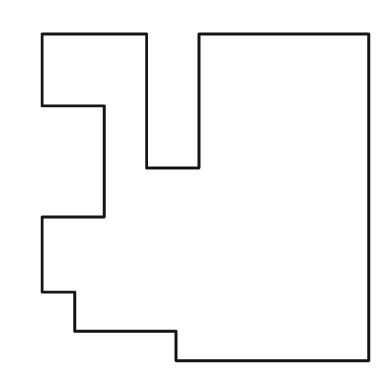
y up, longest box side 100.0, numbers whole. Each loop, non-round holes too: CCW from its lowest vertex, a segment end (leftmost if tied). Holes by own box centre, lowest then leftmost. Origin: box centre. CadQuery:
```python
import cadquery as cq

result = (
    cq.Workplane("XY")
    .moveTo(-9.0, -50.0)
    .lineTo(50.0, -50.0)
    .lineTo(50.0, 50.0)
    .lineTo(-2.0, 50.0)
    .lineTo(-2.0, 9.0)
    .lineTo(-18.0, 9.0)
    .lineTo(-18.0, 50.0)
    .lineTo(-50.0, 50.0)
    .lineTo(-50.0, 28.0)
    .lineTo(-31.0, 28.0)
    .lineTo(-31.0, -6.0)
    .lineTo(-50.0, -6.0)
    .lineTo(-50.0, -29.0)
    .lineTo(-40.0, -29.0)
    .lineTo(-40.0, -41.0)
    .lineTo(-9.0, -41.0)
    .close()
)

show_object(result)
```